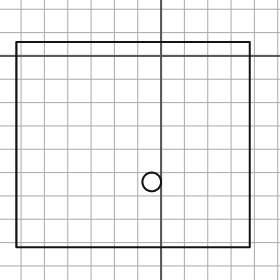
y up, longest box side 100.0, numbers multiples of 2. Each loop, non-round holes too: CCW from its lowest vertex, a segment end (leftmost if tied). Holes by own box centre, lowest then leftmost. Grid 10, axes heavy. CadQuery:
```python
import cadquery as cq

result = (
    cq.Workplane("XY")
    .moveTo(-62.0, -82.0)
    .lineTo(38.0, -82.0)
    .lineTo(38.0, 6.0)
    .lineTo(-62.0, 6.0)
    .close()
    .moveTo(-4.0, -54.0)
    .circle(4.0)
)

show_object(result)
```